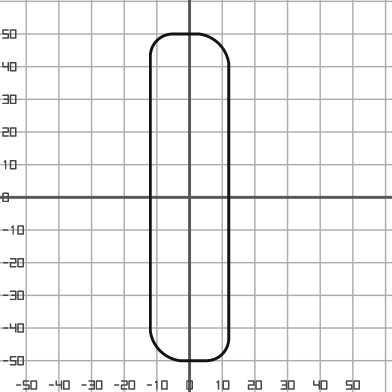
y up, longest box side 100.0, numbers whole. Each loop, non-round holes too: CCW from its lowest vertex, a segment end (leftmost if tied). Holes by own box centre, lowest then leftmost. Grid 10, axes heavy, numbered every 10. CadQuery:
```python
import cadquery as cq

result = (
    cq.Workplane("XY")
    .moveTo(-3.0, -50.0)
    .lineTo(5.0, -50.0)
    .threePointArc((10.0, -48.0), (12.0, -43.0))
    .lineTo(12.0, 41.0)
    .threePointArc((9.0, 47.0), (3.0, 50.0))
    .lineTo(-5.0, 50.0)
    .threePointArc((-10.0, 48.0), (-12.0, 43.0))
    .lineTo(-12.0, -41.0)
    .threePointArc((-9.0, -47.0), (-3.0, -50.0))
    .close()
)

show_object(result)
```